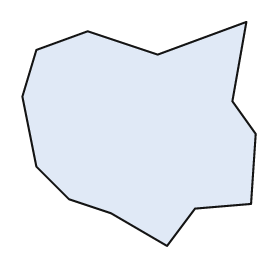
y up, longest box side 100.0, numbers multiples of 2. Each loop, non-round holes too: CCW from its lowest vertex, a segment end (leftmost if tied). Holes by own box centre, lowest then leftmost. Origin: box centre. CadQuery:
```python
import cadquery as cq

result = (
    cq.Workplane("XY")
    .moveTo(12.0, -48.0)
    .lineTo(24.0, -32.0)
    .lineTo(48.0, -30.0)
    .lineTo(50.0, 0.0)
    .lineTo(40.0, 14.0)
    .lineTo(46.0, 48.0)
    .lineTo(8.0, 34.0)
    .lineTo(-22.0, 44.0)
    .lineTo(-44.0, 36.0)
    .lineTo(-50.0, 16.0)
    .lineTo(-44.0, -14.0)
    .lineTo(-30.0, -28.0)
    .lineTo(-12.0, -34.0)
    .close()
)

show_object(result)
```